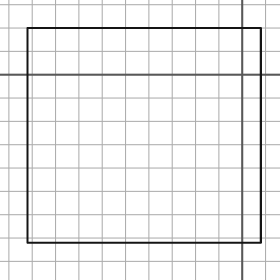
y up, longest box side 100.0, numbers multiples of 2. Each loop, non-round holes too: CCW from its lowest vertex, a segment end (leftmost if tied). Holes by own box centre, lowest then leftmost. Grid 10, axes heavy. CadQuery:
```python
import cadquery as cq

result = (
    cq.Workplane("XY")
    .moveTo(-92.0, -72.0)
    .lineTo(8.0, -72.0)
    .lineTo(8.0, 20.0)
    .lineTo(-92.0, 20.0)
    .close()
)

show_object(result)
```